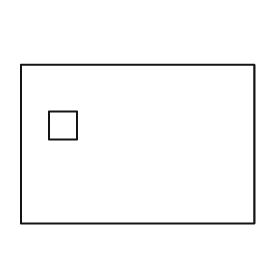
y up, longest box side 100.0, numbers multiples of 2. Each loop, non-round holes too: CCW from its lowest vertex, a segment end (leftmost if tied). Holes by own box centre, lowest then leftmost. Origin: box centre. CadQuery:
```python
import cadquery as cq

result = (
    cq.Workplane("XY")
    .moveTo(-50.0, -34.0)
    .lineTo(50.0, -34.0)
    .lineTo(50.0, 34.0)
    .lineTo(-50.0, 34.0)
    .close()
    .moveTo(-38.0, 2.0)
    .lineTo(-26.0, 2.0)
    .lineTo(-26.0, 14.0)
    .lineTo(-38.0, 14.0)
    .close()
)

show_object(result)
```